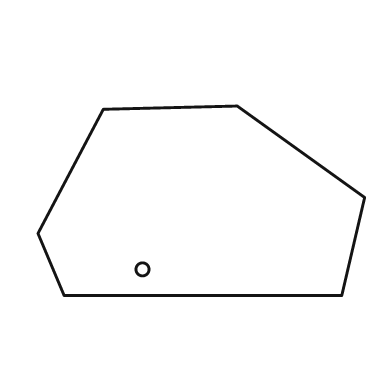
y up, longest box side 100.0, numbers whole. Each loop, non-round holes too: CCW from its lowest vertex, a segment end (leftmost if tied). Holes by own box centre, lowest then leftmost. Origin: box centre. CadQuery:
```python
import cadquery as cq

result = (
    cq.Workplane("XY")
    .moveTo(-42.0, -29.0)
    .lineTo(43.0, -29.0)
    .lineTo(50.0, 1.0)
    .lineTo(11.0, 29.0)
    .lineTo(-30.0, 28.0)
    .lineTo(-50.0, -10.0)
    .close()
    .moveTo(-18.0, -21.0)
    .circle(2.0)
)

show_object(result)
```